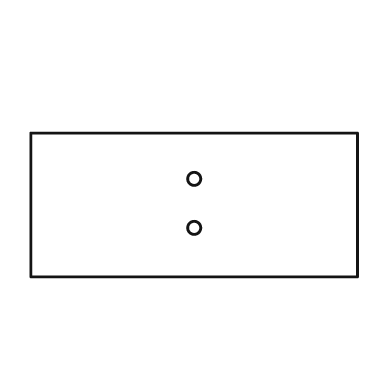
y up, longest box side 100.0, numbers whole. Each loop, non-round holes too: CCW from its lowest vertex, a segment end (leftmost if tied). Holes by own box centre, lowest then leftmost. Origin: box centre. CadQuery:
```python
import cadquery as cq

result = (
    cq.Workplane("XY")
    .moveTo(-50.0, -22.0)
    .lineTo(50.0, -22.0)
    .lineTo(50.0, 22.0)
    .lineTo(-50.0, 22.0)
    .close()
    .moveTo(0.0, -7.0)
    .circle(2.0)
    .moveTo(0.0, 8.0)
    .circle(2.0)
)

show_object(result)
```